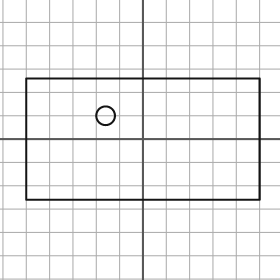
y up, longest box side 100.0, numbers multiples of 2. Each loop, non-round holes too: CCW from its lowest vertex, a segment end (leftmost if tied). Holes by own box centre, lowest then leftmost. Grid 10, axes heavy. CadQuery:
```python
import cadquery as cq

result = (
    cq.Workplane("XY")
    .moveTo(-50.0, -26.0)
    .lineTo(50.0, -26.0)
    .lineTo(50.0, 26.0)
    .lineTo(-50.0, 26.0)
    .close()
    .moveTo(-16.0, 10.0)
    .circle(4.0)
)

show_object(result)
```